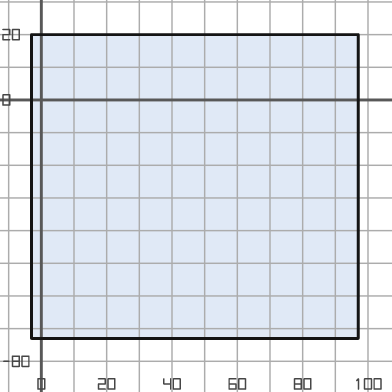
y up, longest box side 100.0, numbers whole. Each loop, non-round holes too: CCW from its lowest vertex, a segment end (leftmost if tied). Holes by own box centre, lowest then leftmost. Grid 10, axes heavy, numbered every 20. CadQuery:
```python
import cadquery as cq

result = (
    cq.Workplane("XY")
    .moveTo(-3.0, -73.0)
    .lineTo(97.0, -73.0)
    .lineTo(97.0, 20.0)
    .lineTo(-3.0, 20.0)
    .close()
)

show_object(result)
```